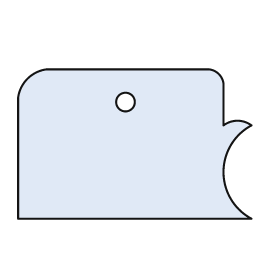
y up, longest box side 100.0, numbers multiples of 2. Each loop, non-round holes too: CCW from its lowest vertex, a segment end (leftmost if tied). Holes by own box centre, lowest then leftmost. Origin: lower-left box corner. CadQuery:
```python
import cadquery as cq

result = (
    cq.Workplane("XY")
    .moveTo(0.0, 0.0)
    .lineTo(100.0, 0.0)
    .threePointArc((88.0, 20.0), (100.0, 40.0))
    .threePointArc((94.0, 42.0), (88.0, 40.0))
    .lineTo(88.0, 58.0)
    .threePointArc((86.0, 62.0), (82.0, 64.0))
    .lineTo(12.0, 64.0)
    .threePointArc((4.0, 60.0), (0.0, 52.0))
    .close()
    .moveTo(46.0, 50.0)
    .circle(4.0)
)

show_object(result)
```